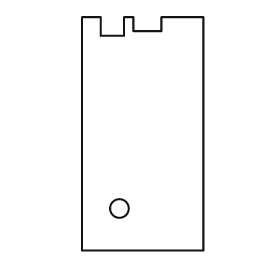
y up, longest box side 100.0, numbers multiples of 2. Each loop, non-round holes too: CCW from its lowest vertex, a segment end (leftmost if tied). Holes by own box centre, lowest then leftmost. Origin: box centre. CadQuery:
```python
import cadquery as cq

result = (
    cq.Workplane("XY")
    .moveTo(-26.0, -50.0)
    .lineTo(26.0, -50.0)
    .lineTo(26.0, 50.0)
    .lineTo(8.0, 50.0)
    .lineTo(8.0, 44.0)
    .lineTo(-4.0, 44.0)
    .lineTo(-4.0, 50.0)
    .lineTo(-8.0, 50.0)
    .lineTo(-8.0, 42.0)
    .lineTo(-18.0, 42.0)
    .lineTo(-18.0, 50.0)
    .lineTo(-26.0, 50.0)
    .close()
    .moveTo(-10.0, -32.0)
    .circle(4.0)
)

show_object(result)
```